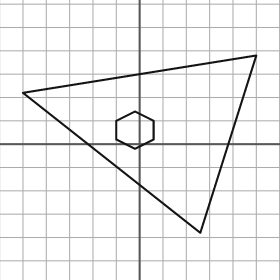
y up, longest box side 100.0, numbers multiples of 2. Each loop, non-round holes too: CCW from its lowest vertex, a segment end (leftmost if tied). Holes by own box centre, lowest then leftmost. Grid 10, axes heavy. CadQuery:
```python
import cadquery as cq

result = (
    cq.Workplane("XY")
    .moveTo(26.0, -38.0)
    .lineTo(50.0, 38.0)
    .lineTo(-50.0, 22.0)
    .close()
    .moveTo(-2.0, -2.0)
    .lineTo(6.0, 2.0)
    .lineTo(6.0, 10.0)
    .lineTo(-2.0, 14.0)
    .lineTo(-10.0, 10.0)
    .lineTo(-10.0, 2.0)
    .close()
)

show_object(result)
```